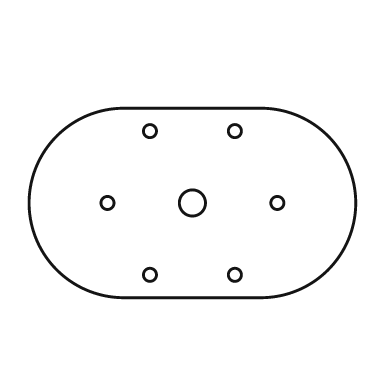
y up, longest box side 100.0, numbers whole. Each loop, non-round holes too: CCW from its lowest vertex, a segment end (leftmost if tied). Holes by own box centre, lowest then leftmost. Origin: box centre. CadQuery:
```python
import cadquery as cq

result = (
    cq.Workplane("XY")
    .moveTo(-21.0, -29.0)
    .lineTo(21.0, -29.0)
    .threePointArc((50.0, 0.0), (21.0, 29.0))
    .lineTo(-21.0, 29.0)
    .threePointArc((-50.0, 0.0), (-21.0, -29.0))
    .close()
    .moveTo(-13.0, -22.0)
    .circle(2.0)
    .moveTo(13.0, -22.0)
    .circle(2.0)
    .moveTo(-26.0, 0.0)
    .circle(2.0)
    .moveTo(0.0, 0.0)
    .circle(4.0)
    .moveTo(26.0, 0.0)
    .circle(2.0)
    .moveTo(-13.0, 22.0)
    .circle(2.0)
    .moveTo(13.0, 22.0)
    .circle(2.0)
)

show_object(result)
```